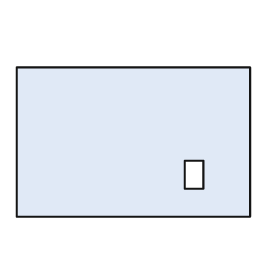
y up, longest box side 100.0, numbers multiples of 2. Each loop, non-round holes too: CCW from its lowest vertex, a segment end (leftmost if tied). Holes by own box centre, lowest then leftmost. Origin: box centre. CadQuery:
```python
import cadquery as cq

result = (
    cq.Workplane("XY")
    .moveTo(-50.0, -32.0)
    .lineTo(50.0, -32.0)
    .lineTo(50.0, 32.0)
    .lineTo(-50.0, 32.0)
    .close()
    .moveTo(22.0, -20.0)
    .lineTo(30.0, -20.0)
    .lineTo(30.0, -8.0)
    .lineTo(22.0, -8.0)
    .close()
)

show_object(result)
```